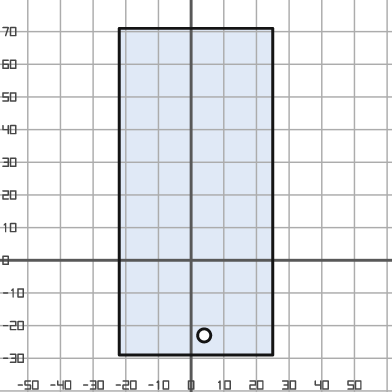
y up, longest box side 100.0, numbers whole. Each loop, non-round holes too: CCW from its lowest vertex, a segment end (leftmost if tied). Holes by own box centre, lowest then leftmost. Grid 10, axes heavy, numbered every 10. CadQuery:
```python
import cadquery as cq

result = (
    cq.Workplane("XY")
    .moveTo(-22.0, -29.0)
    .lineTo(25.0, -29.0)
    .lineTo(25.0, 71.0)
    .lineTo(-22.0, 71.0)
    .close()
    .moveTo(4.0, -23.0)
    .circle(2.0)
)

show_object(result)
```